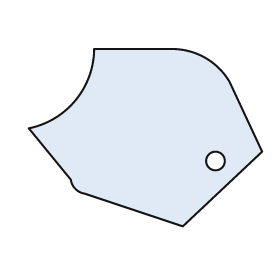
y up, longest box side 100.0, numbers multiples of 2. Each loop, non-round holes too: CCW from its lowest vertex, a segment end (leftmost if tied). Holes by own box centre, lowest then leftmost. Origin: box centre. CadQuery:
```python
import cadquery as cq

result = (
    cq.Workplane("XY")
    .moveTo(16.0, -38.0)
    .lineTo(50.0, -6.0)
    .lineTo(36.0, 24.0)
    .threePointArc((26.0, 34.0), (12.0, 38.0))
    .lineTo(-22.0, 38.0)
    .threePointArc((-30.0, 16.0), (-50.0, 4.0))
    .lineTo(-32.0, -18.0)
    .threePointArc((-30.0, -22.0), (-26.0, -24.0))
    .close()
    .moveTo(30.0, -10.0)
    .circle(4.0)
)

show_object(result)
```